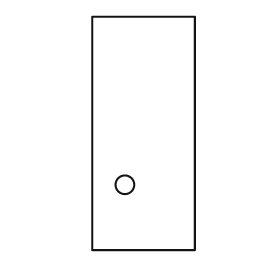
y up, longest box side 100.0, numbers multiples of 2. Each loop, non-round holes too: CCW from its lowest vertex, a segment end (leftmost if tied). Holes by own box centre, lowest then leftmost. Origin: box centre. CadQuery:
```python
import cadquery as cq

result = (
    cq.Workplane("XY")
    .moveTo(-22.0, -50.0)
    .lineTo(22.0, -50.0)
    .lineTo(22.0, 50.0)
    .lineTo(-22.0, 50.0)
    .close()
    .moveTo(-8.0, -22.0)
    .circle(4.0)
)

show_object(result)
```